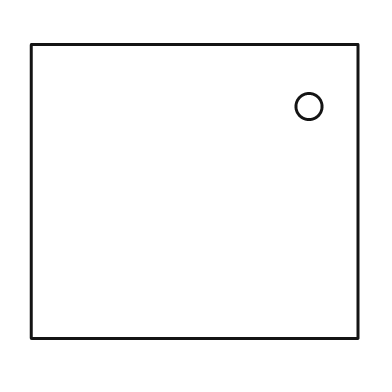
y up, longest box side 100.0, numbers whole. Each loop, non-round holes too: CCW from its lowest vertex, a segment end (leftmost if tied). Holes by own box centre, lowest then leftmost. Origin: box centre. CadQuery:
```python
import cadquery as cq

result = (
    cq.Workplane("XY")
    .moveTo(-50.0, -45.0)
    .lineTo(50.0, -45.0)
    .lineTo(50.0, 45.0)
    .lineTo(-50.0, 45.0)
    .close()
    .moveTo(35.0, 26.0)
    .circle(4.0)
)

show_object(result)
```